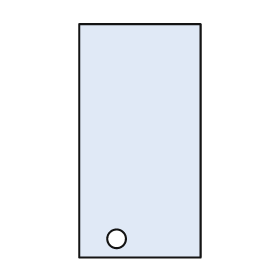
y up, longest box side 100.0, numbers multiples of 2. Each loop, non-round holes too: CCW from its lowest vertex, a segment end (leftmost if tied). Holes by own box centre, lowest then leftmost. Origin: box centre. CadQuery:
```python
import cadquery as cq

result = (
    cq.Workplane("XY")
    .moveTo(-26.0, -50.0)
    .lineTo(26.0, -50.0)
    .lineTo(26.0, 50.0)
    .lineTo(-26.0, 50.0)
    .close()
    .moveTo(-10.0, -42.0)
    .circle(4.0)
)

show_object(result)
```